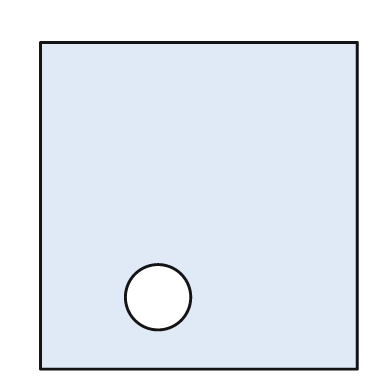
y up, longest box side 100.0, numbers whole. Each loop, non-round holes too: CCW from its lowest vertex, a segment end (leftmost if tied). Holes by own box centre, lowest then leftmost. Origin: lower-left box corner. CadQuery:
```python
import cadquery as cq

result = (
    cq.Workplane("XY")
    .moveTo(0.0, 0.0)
    .lineTo(97.0, 0.0)
    .lineTo(97.0, 100.0)
    .lineTo(0.0, 100.0)
    .close()
    .moveTo(36.0, 22.0)
    .circle(10.0)
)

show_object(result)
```